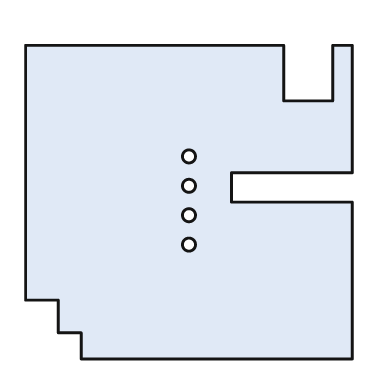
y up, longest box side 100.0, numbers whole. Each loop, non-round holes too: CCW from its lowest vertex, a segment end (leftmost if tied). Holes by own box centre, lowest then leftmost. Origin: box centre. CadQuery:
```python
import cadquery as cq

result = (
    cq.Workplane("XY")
    .moveTo(-33.0, -48.0)
    .lineTo(50.0, -48.0)
    .lineTo(50.0, 0.0)
    .lineTo(13.0, 0.0)
    .lineTo(13.0, 9.0)
    .lineTo(50.0, 9.0)
    .lineTo(50.0, 48.0)
    .lineTo(44.0, 48.0)
    .lineTo(44.0, 31.0)
    .lineTo(29.0, 31.0)
    .lineTo(29.0, 48.0)
    .lineTo(-50.0, 48.0)
    .lineTo(-50.0, -30.0)
    .lineTo(-40.0, -30.0)
    .lineTo(-40.0, -40.0)
    .lineTo(-33.0, -40.0)
    .close()
    .moveTo(0.0, -13.0)
    .circle(2.0)
    .moveTo(0.0, -4.0)
    .circle(2.0)
    .moveTo(0.0, 5.0)
    .circle(2.0)
    .moveTo(0.0, 14.0)
    .circle(2.0)
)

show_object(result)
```